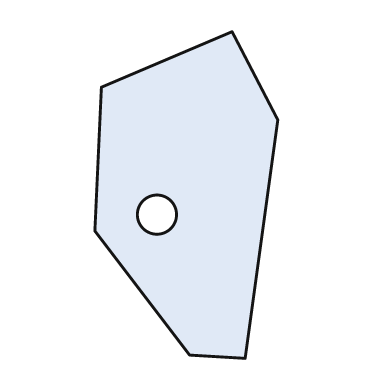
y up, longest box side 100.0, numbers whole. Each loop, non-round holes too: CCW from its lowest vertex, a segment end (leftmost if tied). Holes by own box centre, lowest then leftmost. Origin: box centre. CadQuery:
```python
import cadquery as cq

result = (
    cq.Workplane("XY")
    .moveTo(18.0, -50.0)
    .lineTo(28.0, 23.0)
    .lineTo(14.0, 50.0)
    .lineTo(-26.0, 33.0)
    .lineTo(-28.0, -11.0)
    .lineTo(1.0, -49.0)
    .close()
    .moveTo(-9.0, -6.0)
    .circle(6.0)
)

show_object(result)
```